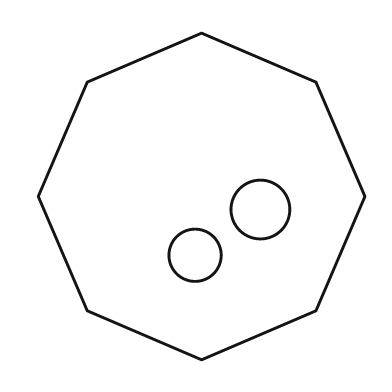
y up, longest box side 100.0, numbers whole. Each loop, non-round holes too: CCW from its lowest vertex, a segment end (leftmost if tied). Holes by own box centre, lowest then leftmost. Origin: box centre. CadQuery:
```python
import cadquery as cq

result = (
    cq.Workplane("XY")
    .moveTo(0.0, -50.0)
    .lineTo(35.0, -35.0)
    .lineTo(50.0, 0.0)
    .lineTo(35.0, 35.0)
    .lineTo(0.0, 50.0)
    .lineTo(-35.0, 35.0)
    .lineTo(-50.0, 0.0)
    .lineTo(-35.0, -35.0)
    .close()
    .moveTo(-2.0, -18.0)
    .circle(8.0)
    .moveTo(18.0, -4.0)
    .circle(9.0)
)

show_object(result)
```